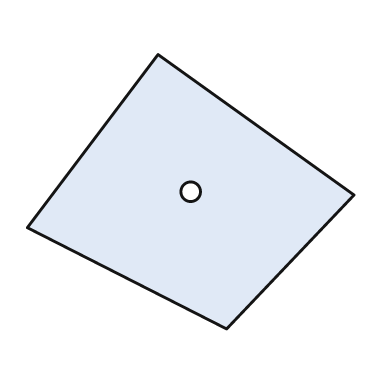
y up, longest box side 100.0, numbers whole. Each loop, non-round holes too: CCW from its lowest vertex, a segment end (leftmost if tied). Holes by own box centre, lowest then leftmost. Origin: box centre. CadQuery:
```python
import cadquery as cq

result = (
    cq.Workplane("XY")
    .moveTo(11.0, -42.0)
    .lineTo(50.0, -1.0)
    .lineTo(-10.0, 42.0)
    .lineTo(-50.0, -11.0)
    .close()
    .moveTo(0.0, 0.0)
    .circle(3.0)
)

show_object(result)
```